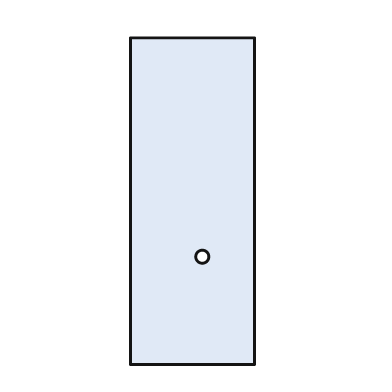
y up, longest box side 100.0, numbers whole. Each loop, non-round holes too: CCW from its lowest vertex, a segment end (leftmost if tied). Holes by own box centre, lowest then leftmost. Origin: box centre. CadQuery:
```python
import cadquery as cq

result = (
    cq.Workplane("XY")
    .moveTo(-19.0, -50.0)
    .lineTo(19.0, -50.0)
    .lineTo(19.0, 50.0)
    .lineTo(-19.0, 50.0)
    .close()
    .moveTo(3.0, -17.0)
    .circle(2.0)
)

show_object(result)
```